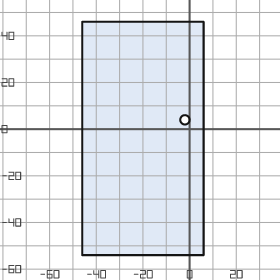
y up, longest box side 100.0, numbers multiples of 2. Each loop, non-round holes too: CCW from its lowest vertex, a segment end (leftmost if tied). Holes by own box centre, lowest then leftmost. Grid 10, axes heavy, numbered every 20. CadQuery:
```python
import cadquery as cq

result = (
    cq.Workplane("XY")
    .moveTo(-46.0, -54.0)
    .lineTo(6.0, -54.0)
    .lineTo(6.0, 46.0)
    .lineTo(-46.0, 46.0)
    .close()
    .moveTo(-2.0, 4.0)
    .circle(2.0)
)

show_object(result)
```